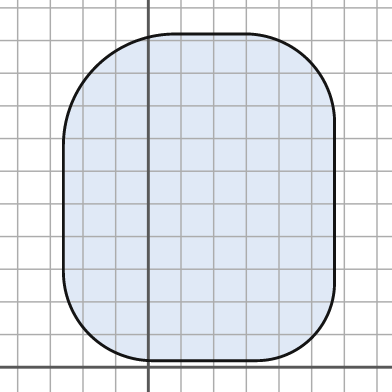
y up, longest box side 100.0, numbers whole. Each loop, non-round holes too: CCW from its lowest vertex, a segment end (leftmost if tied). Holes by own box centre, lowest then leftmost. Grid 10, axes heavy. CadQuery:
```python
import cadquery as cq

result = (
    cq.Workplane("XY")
    .moveTo(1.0, 2.0)
    .lineTo(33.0, 2.0)
    .threePointArc((50.0, 9.0), (57.0, 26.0))
    .lineTo(57.0, 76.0)
    .threePointArc((49.0, 94.0), (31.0, 102.0))
    .lineTo(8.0, 102.0)
    .threePointArc((-16.0, 92.0), (-26.0, 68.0))
    .lineTo(-26.0, 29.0)
    .threePointArc((-18.0, 10.0), (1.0, 2.0))
    .close()
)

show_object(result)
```